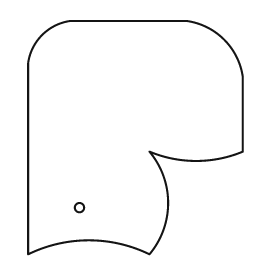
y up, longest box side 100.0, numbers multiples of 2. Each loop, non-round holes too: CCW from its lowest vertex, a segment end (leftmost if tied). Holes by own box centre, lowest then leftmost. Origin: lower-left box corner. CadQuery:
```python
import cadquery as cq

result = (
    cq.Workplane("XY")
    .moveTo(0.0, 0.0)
    .threePointArc((26.0, 6.0), (52.0, 0.0))
    .threePointArc((60.0, 22.0), (52.0, 44.0))
    .threePointArc((72.0, 40.0), (92.0, 44.0))
    .lineTo(92.0, 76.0)
    .threePointArc((84.0, 92.0), (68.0, 100.0))
    .lineTo(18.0, 100.0)
    .threePointArc((6.0, 94.0), (0.0, 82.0))
    .close()
    .moveTo(22.0, 20.0)
    .circle(2.0)
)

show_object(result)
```